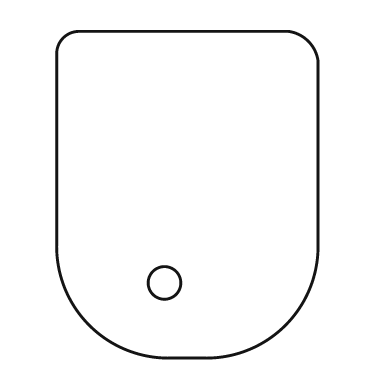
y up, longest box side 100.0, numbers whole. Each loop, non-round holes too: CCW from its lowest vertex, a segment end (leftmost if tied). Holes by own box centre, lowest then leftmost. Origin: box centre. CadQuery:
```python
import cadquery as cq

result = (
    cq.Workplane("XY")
    .moveTo(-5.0, -50.0)
    .lineTo(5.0, -50.0)
    .threePointArc((30.0, -40.0), (40.0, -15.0))
    .lineTo(40.0, 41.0)
    .threePointArc((37.0, 47.0), (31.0, 50.0))
    .lineTo(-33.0, 50.0)
    .threePointArc((-38.0, 48.0), (-40.0, 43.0))
    .lineTo(-40.0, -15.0)
    .threePointArc((-30.0, -40.0), (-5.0, -50.0))
    .close()
    .moveTo(-7.0, -27.0)
    .circle(5.0)
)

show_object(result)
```